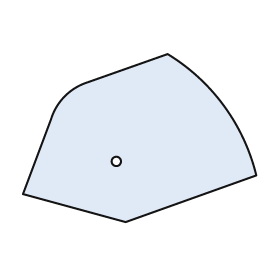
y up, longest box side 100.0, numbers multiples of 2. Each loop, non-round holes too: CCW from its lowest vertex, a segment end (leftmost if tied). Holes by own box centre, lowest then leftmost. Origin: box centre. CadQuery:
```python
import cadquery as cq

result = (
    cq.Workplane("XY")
    .moveTo(-6.0, -36.0)
    .lineTo(50.0, -16.0)
    .threePointArc((36.0, 14.0), (12.0, 36.0))
    .lineTo(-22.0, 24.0)
    .threePointArc((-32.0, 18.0), (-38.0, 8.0))
    .lineTo(-50.0, -24.0)
    .close()
    .moveTo(-10.0, -10.0)
    .circle(2.0)
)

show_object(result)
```